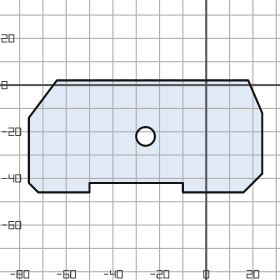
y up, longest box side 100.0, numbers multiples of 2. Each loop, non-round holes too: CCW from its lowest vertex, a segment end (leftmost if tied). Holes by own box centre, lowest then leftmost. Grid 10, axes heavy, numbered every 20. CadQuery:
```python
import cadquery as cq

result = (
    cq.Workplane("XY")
    .moveTo(-72.0, -46.0)
    .lineTo(-50.0, -46.0)
    .lineTo(-50.0, -42.0)
    .lineTo(-10.0, -42.0)
    .lineTo(-10.0, -46.0)
    .lineTo(16.0, -46.0)
    .lineTo(24.0, -38.0)
    .lineTo(24.0, -12.0)
    .lineTo(18.0, 2.0)
    .lineTo(-64.0, 2.0)
    .lineTo(-76.0, -14.0)
    .lineTo(-76.0, -42.0)
    .close()
    .moveTo(-26.0, -22.0)
    .circle(4.0)
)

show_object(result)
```